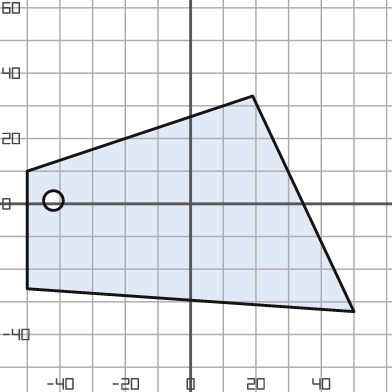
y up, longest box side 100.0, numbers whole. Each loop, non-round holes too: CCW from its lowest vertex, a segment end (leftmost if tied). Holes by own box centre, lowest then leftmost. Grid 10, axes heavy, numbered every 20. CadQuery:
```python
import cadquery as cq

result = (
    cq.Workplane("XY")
    .moveTo(50.0, -33.0)
    .lineTo(19.0, 33.0)
    .lineTo(-50.0, 10.0)
    .lineTo(-50.0, -26.0)
    .close()
    .moveTo(-42.0, 1.0)
    .circle(3.0)
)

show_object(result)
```